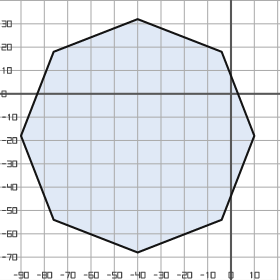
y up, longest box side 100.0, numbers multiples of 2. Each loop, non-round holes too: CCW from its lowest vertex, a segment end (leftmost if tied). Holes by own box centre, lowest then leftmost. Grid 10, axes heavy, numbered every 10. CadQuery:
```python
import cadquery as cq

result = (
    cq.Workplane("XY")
    .moveTo(-40.0, -68.0)
    .lineTo(-4.0, -54.0)
    .lineTo(10.0, -18.0)
    .lineTo(-4.0, 18.0)
    .lineTo(-40.0, 32.0)
    .lineTo(-76.0, 18.0)
    .lineTo(-90.0, -18.0)
    .lineTo(-76.0, -54.0)
    .close()
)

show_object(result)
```